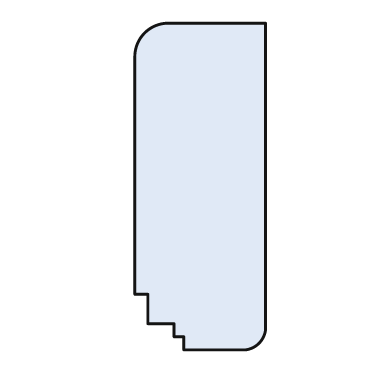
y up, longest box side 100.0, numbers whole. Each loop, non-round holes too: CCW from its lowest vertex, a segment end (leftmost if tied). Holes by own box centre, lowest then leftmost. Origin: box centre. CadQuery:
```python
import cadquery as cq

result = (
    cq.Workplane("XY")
    .moveTo(-5.0, -50.0)
    .lineTo(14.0, -50.0)
    .threePointArc((18.0, -48.0), (20.0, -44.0))
    .lineTo(20.0, 50.0)
    .lineTo(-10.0, 50.0)
    .threePointArc((-17.0, 47.0), (-20.0, 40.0))
    .lineTo(-20.0, -33.0)
    .lineTo(-16.0, -33.0)
    .lineTo(-16.0, -42.0)
    .lineTo(-8.0, -42.0)
    .lineTo(-8.0, -46.0)
    .lineTo(-5.0, -46.0)
    .close()
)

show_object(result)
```